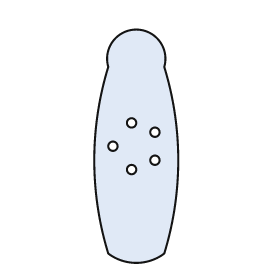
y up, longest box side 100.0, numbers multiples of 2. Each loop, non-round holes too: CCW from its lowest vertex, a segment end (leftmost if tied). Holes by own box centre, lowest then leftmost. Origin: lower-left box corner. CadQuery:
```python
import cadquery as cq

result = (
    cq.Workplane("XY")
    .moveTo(6.0, 4.0)
    .threePointArc((18.0, 0.0), (30.0, 4.0))
    .threePointArc((36.0, 44.0), (30.0, 84.0))
    .threePointArc((18.0, 100.0), (6.0, 84.0))
    .threePointArc((0.0, 44.0), (6.0, 4.0))
    .close()
    .moveTo(16.0, 40.0)
    .circle(2.0)
    .moveTo(26.0, 44.0)
    .circle(2.0)
    .moveTo(8.0, 50.0)
    .circle(2.0)
    .moveTo(26.0, 56.0)
    .circle(2.0)
    .moveTo(16.0, 60.0)
    .circle(2.0)
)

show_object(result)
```